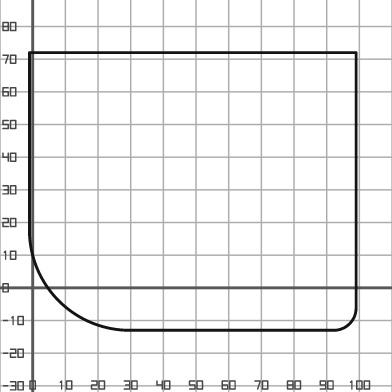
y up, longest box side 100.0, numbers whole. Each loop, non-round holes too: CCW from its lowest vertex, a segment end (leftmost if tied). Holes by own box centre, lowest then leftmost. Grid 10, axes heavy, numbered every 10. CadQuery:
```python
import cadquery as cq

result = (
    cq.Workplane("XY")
    .moveTo(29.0, -13.0)
    .lineTo(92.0, -13.0)
    .threePointArc((97.0, -11.0), (99.0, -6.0))
    .lineTo(99.0, 72.0)
    .lineTo(-1.0, 72.0)
    .lineTo(-1.0, 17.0)
    .threePointArc((8.0, -4.0), (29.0, -13.0))
    .close()
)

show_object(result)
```